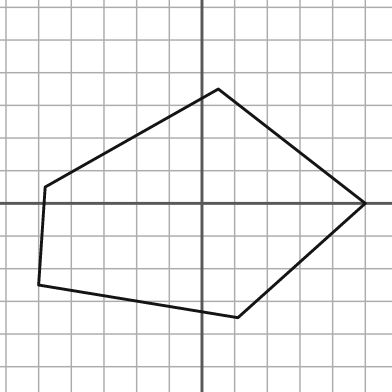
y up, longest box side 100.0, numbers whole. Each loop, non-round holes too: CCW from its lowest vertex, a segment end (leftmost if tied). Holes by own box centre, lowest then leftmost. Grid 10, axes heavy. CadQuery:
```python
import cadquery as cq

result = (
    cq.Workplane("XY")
    .moveTo(11.0, -35.0)
    .lineTo(50.0, 0.0)
    .lineTo(5.0, 35.0)
    .lineTo(-48.0, 5.0)
    .lineTo(-50.0, -25.0)
    .close()
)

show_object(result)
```